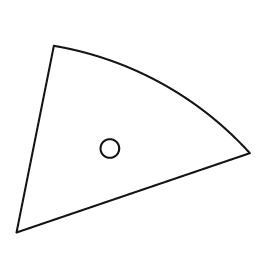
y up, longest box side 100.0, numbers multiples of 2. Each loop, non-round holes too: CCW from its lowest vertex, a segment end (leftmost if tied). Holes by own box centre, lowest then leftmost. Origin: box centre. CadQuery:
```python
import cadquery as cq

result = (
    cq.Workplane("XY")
    .moveTo(-50.0, -40.0)
    .lineTo(50.0, -6.0)
    .threePointArc((12.0, 24.0), (-34.0, 40.0))
    .close()
    .moveTo(-10.0, -4.0)
    .circle(4.0)
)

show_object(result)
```